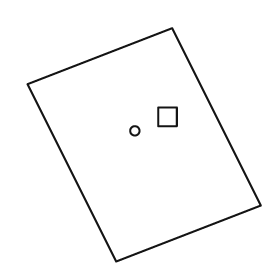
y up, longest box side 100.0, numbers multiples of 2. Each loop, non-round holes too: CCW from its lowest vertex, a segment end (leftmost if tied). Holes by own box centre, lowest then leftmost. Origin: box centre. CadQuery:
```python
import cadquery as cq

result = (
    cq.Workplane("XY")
    .moveTo(-12.0, -50.0)
    .lineTo(50.0, -26.0)
    .lineTo(12.0, 50.0)
    .lineTo(-50.0, 26.0)
    .close()
    .moveTo(-4.0, 6.0)
    .circle(2.0)
    .moveTo(6.0, 8.0)
    .lineTo(14.0, 8.0)
    .lineTo(14.0, 16.0)
    .lineTo(6.0, 16.0)
    .close()
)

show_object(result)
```